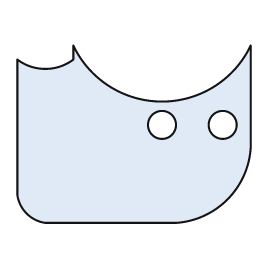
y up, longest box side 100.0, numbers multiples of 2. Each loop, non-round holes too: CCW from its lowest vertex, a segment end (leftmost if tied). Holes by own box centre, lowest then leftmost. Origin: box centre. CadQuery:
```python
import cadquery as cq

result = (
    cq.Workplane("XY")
    .moveTo(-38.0, -38.0)
    .lineTo(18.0, -38.0)
    .threePointArc((40.0, -28.0), (50.0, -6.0))
    .lineTo(50.0, 38.0)
    .threePointArc((12.0, 14.0), (-26.0, 38.0))
    .lineTo(-26.0, 32.0)
    .threePointArc((-38.0, 28.0), (-50.0, 32.0))
    .lineTo(-50.0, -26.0)
    .threePointArc((-46.0, -34.0), (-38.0, -38.0))
    .close()
    .moveTo(12.0, 4.0)
    .circle(6.0)
    .moveTo(38.0, 4.0)
    .circle(6.0)
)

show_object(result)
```